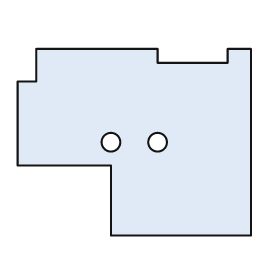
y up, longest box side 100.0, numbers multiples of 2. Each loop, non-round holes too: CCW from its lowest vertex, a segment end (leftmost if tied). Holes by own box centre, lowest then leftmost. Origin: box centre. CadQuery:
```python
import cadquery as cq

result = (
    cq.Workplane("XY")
    .moveTo(-10.0, -40.0)
    .lineTo(50.0, -40.0)
    .lineTo(50.0, 40.0)
    .lineTo(40.0, 40.0)
    .lineTo(40.0, 34.0)
    .lineTo(10.0, 34.0)
    .lineTo(10.0, 40.0)
    .lineTo(-42.0, 40.0)
    .lineTo(-42.0, 26.0)
    .lineTo(-50.0, 26.0)
    .lineTo(-50.0, -10.0)
    .lineTo(-10.0, -10.0)
    .close()
    .moveTo(-10.0, 0.0)
    .circle(4.0)
    .moveTo(10.0, 0.0)
    .circle(4.0)
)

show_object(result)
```